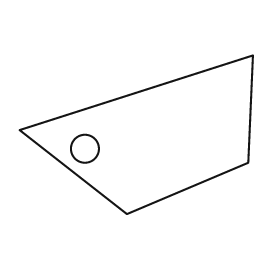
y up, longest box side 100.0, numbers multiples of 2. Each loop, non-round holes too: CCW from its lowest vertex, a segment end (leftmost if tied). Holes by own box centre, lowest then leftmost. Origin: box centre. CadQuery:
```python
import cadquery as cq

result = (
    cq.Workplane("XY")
    .moveTo(-4.0, -34.0)
    .lineTo(48.0, -12.0)
    .lineTo(50.0, 34.0)
    .lineTo(-50.0, 2.0)
    .close()
    .moveTo(-22.0, -6.0)
    .circle(6.0)
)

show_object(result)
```